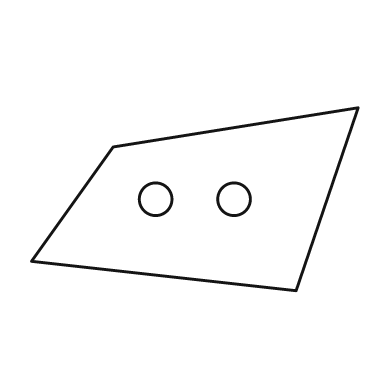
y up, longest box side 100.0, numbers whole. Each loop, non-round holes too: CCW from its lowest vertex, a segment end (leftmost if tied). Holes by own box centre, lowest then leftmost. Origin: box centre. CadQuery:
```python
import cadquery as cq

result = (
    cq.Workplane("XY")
    .moveTo(31.0, -28.0)
    .lineTo(50.0, 28.0)
    .lineTo(-25.0, 16.0)
    .lineTo(-50.0, -19.0)
    .close()
    .moveTo(-12.0, 0.0)
    .circle(5.0)
    .moveTo(12.0, 0.0)
    .circle(5.0)
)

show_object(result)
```